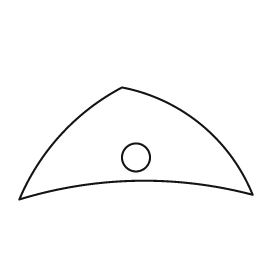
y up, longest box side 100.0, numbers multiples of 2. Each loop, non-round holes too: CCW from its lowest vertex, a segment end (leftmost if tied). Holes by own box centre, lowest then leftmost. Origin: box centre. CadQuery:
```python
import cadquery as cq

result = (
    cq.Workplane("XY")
    .moveTo(-50.0, -24.0)
    .threePointArc((0.0, -16.0), (50.0, -22.0))
    .threePointArc((28.0, 8.0), (-6.0, 24.0))
    .threePointArc((-32.0, 4.0), (-50.0, -24.0))
    .close()
    .moveTo(0.0, -6.0)
    .circle(6.0)
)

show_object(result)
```